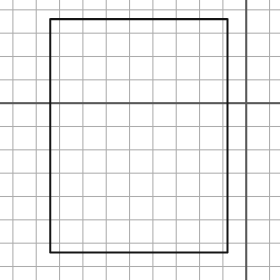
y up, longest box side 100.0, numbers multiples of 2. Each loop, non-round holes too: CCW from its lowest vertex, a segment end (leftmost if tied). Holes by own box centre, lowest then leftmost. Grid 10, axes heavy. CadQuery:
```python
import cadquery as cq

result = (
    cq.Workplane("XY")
    .moveTo(-84.0, -64.0)
    .lineTo(-8.0, -64.0)
    .lineTo(-8.0, 36.0)
    .lineTo(-84.0, 36.0)
    .close()
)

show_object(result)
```